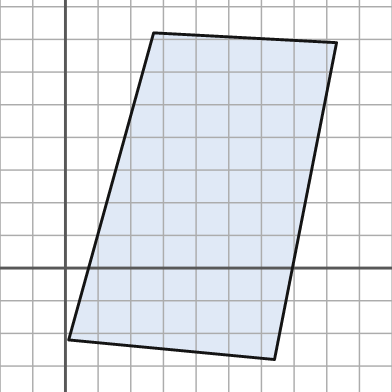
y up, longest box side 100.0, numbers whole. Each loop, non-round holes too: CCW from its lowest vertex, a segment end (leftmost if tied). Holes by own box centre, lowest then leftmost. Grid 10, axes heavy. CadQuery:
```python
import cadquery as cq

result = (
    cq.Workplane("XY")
    .moveTo(64.0, -28.0)
    .lineTo(83.0, 69.0)
    .lineTo(27.0, 72.0)
    .lineTo(1.0, -22.0)
    .close()
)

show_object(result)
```